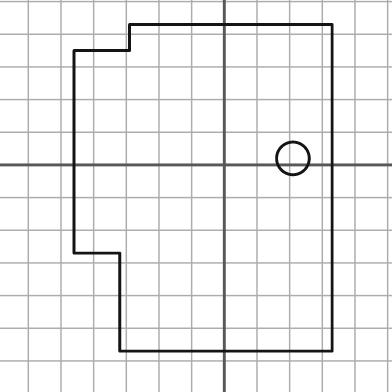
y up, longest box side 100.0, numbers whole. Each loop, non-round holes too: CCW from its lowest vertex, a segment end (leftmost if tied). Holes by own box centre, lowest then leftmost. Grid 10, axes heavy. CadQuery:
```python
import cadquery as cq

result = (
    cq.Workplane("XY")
    .moveTo(-32.0, -57.0)
    .lineTo(33.0, -57.0)
    .lineTo(33.0, 43.0)
    .lineTo(-29.0, 43.0)
    .lineTo(-29.0, 35.0)
    .lineTo(-46.0, 35.0)
    .lineTo(-46.0, -27.0)
    .lineTo(-32.0, -27.0)
    .close()
    .moveTo(21.0, 2.0)
    .circle(5.0)
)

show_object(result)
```